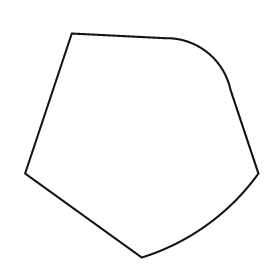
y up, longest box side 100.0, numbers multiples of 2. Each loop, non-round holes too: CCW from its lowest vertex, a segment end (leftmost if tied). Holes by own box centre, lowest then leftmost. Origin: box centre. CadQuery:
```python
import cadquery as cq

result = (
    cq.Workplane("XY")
    .moveTo(0.0, -48.0)
    .threePointArc((28.0, -34.0), (50.0, -12.0))
    .lineTo(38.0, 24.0)
    .threePointArc((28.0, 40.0), (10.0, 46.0))
    .lineTo(-30.0, 48.0)
    .lineTo(-50.0, -12.0)
    .close()
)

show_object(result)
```